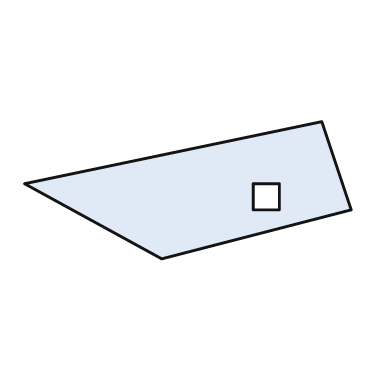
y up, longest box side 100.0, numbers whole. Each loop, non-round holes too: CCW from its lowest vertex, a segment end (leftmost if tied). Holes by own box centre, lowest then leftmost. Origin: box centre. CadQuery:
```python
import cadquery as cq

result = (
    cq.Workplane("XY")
    .moveTo(-8.0, -21.0)
    .lineTo(50.0, -6.0)
    .lineTo(41.0, 21.0)
    .lineTo(-50.0, 2.0)
    .close()
    .moveTo(20.0, -6.0)
    .lineTo(28.0, -6.0)
    .lineTo(28.0, 2.0)
    .lineTo(20.0, 2.0)
    .close()
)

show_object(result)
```